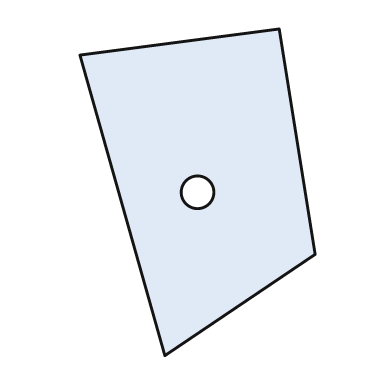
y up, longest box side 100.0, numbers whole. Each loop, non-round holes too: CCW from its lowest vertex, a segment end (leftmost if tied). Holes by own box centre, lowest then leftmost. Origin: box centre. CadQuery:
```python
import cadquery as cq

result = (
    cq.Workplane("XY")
    .moveTo(-10.0, -50.0)
    .lineTo(36.0, -19.0)
    .lineTo(25.0, 50.0)
    .lineTo(-36.0, 42.0)
    .close()
    .moveTo(0.0, 0.0)
    .circle(5.0)
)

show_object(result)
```